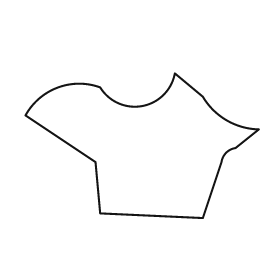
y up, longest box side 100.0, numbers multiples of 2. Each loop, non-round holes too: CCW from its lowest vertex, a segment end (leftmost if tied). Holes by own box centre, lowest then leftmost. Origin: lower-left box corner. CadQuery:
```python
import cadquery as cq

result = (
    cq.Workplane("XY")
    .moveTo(76.0, 0.0)
    .lineTo(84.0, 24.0)
    .threePointArc((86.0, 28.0), (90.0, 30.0))
    .lineTo(100.0, 38.0)
    .threePointArc((86.0, 42.0), (76.0, 52.0))
    .lineTo(64.0, 62.0)
    .threePointArc((50.0, 48.0), (32.0, 56.0))
    .threePointArc((14.0, 56.0), (0.0, 44.0))
    .lineTo(30.0, 24.0)
    .lineTo(32.0, 2.0)
    .close()
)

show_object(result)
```